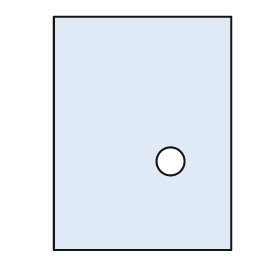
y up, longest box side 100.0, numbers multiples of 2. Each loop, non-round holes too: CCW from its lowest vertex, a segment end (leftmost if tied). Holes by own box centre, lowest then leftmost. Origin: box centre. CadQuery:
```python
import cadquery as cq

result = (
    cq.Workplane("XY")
    .moveTo(-38.0, -50.0)
    .lineTo(38.0, -50.0)
    .lineTo(38.0, 50.0)
    .lineTo(-38.0, 50.0)
    .close()
    .moveTo(12.0, -12.0)
    .circle(6.0)
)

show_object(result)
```